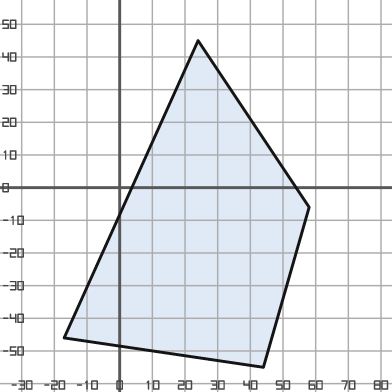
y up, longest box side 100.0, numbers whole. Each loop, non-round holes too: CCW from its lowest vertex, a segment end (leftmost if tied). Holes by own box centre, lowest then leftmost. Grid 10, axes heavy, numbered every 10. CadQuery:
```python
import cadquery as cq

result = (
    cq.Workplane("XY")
    .moveTo(44.0, -55.0)
    .lineTo(58.0, -6.0)
    .lineTo(24.0, 45.0)
    .lineTo(-17.0, -46.0)
    .close()
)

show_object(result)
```